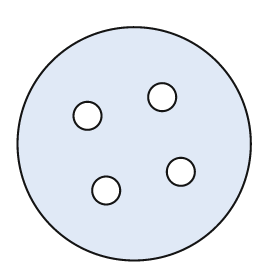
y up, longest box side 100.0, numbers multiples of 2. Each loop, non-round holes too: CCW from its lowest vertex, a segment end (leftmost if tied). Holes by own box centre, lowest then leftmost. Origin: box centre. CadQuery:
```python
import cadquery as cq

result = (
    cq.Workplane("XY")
    .moveTo(0.0, 0.0)
    .circle(50.0)
    .moveTo(-12.0, -20.0)
    .circle(6.0)
    .moveTo(20.0, -12.0)
    .circle(6.0)
    .moveTo(-20.0, 12.0)
    .circle(6.0)
    .moveTo(12.0, 20.0)
    .circle(6.0)
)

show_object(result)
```